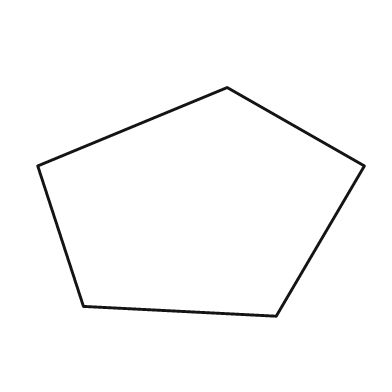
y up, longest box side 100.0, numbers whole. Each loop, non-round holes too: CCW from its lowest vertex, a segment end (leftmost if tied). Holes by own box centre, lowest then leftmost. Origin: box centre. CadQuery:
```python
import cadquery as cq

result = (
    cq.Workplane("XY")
    .moveTo(23.0, -35.0)
    .lineTo(50.0, 11.0)
    .lineTo(8.0, 35.0)
    .lineTo(-50.0, 11.0)
    .lineTo(-36.0, -32.0)
    .close()
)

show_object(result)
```